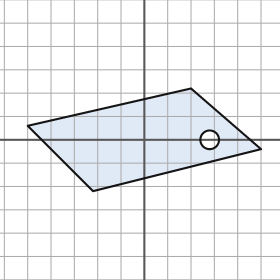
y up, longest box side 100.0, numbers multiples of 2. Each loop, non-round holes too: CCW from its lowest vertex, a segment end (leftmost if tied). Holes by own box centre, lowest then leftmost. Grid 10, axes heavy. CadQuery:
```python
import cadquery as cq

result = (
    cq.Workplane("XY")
    .moveTo(-22.0, -22.0)
    .lineTo(50.0, -4.0)
    .lineTo(20.0, 22.0)
    .lineTo(-50.0, 6.0)
    .close()
    .moveTo(28.0, 0.0)
    .circle(4.0)
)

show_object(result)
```